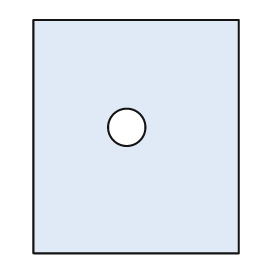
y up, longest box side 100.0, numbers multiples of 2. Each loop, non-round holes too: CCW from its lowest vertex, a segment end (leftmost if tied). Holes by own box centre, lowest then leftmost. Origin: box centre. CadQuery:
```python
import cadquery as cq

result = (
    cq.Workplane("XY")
    .moveTo(-44.0, -50.0)
    .lineTo(44.0, -50.0)
    .lineTo(44.0, 50.0)
    .lineTo(-44.0, 50.0)
    .close()
    .moveTo(-4.0, 4.0)
    .circle(8.0)
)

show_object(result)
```